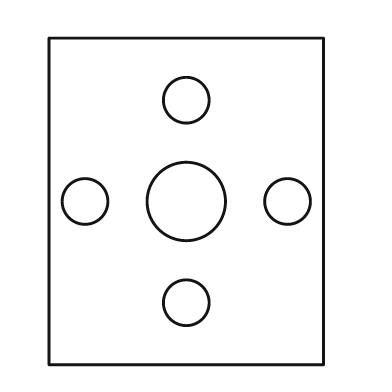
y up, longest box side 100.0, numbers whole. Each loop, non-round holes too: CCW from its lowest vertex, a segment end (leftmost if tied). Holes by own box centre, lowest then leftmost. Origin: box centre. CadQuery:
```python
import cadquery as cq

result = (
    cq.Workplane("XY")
    .moveTo(-42.0, -50.0)
    .lineTo(42.0, -50.0)
    .lineTo(42.0, 50.0)
    .lineTo(-42.0, 50.0)
    .close()
    .moveTo(0.0, -31.0)
    .circle(7.0)
    .moveTo(-31.0, 0.0)
    .circle(7.0)
    .moveTo(0.0, 0.0)
    .circle(12.0)
    .moveTo(31.0, 0.0)
    .circle(7.0)
    .moveTo(0.0, 31.0)
    .circle(7.0)
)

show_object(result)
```